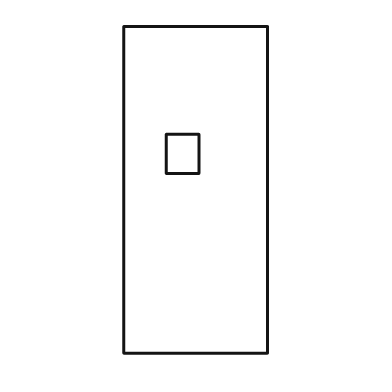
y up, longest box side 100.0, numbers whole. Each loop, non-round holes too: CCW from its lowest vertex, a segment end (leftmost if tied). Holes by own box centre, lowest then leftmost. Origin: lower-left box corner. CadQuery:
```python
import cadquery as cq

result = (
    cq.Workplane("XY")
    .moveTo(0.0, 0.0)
    .lineTo(44.0, 0.0)
    .lineTo(44.0, 100.0)
    .lineTo(0.0, 100.0)
    .close()
    .moveTo(13.0, 55.0)
    .lineTo(23.0, 55.0)
    .lineTo(23.0, 67.0)
    .lineTo(13.0, 67.0)
    .close()
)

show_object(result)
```